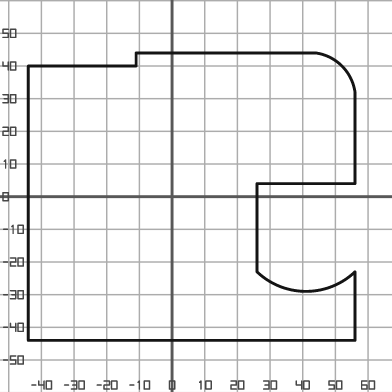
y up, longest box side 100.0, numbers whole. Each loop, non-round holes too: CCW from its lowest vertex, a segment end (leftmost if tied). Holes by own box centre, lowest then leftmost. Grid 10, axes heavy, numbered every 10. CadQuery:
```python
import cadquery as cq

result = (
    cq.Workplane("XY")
    .moveTo(-44.0, -44.0)
    .lineTo(56.0, -44.0)
    .lineTo(56.0, -23.0)
    .threePointArc((41.0, -29.0), (26.0, -23.0))
    .lineTo(26.0, 4.0)
    .lineTo(56.0, 4.0)
    .lineTo(56.0, 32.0)
    .threePointArc((52.0, 40.0), (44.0, 44.0))
    .lineTo(-11.0, 44.0)
    .lineTo(-11.0, 40.0)
    .lineTo(-44.0, 40.0)
    .close()
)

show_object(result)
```